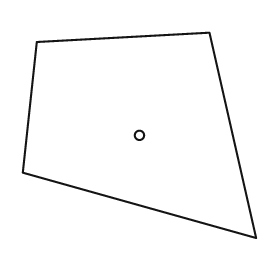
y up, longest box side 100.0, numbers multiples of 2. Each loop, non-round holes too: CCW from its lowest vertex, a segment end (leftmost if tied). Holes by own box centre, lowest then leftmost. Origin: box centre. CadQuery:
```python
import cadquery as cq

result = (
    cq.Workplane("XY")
    .moveTo(50.0, -44.0)
    .lineTo(30.0, 44.0)
    .lineTo(-44.0, 40.0)
    .lineTo(-50.0, -16.0)
    .close()
    .moveTo(0.0, 0.0)
    .circle(2.0)
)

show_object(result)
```